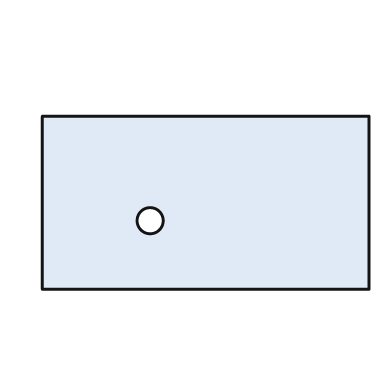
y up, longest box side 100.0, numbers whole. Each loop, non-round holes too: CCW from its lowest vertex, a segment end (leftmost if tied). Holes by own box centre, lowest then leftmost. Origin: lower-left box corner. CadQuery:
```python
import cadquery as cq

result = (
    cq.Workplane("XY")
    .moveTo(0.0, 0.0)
    .lineTo(100.0, 0.0)
    .lineTo(100.0, 53.0)
    .lineTo(0.0, 53.0)
    .close()
    .moveTo(33.0, 21.0)
    .circle(4.0)
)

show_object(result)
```